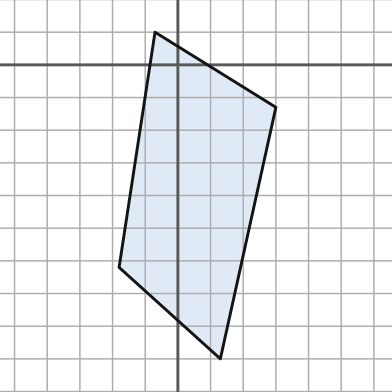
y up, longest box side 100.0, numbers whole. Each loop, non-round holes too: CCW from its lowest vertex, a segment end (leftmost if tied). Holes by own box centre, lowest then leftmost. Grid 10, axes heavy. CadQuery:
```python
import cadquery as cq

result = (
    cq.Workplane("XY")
    .moveTo(13.0, -90.0)
    .lineTo(30.0, -13.0)
    .lineTo(-7.0, 10.0)
    .lineTo(-18.0, -62.0)
    .close()
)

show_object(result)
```